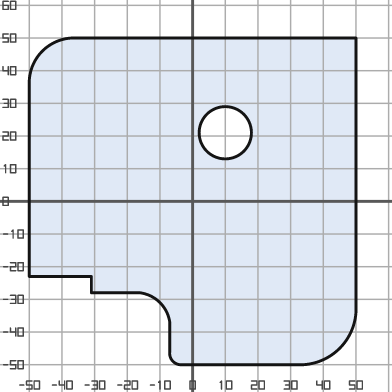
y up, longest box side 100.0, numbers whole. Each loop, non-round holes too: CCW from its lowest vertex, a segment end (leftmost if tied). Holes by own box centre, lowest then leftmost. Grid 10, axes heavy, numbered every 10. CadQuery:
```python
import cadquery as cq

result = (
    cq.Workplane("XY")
    .moveTo(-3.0, -50.0)
    .lineTo(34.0, -50.0)
    .threePointArc((45.0, -45.0), (50.0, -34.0))
    .lineTo(50.0, 50.0)
    .lineTo(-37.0, 50.0)
    .threePointArc((-46.0, 46.0), (-50.0, 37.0))
    .lineTo(-50.0, -23.0)
    .lineTo(-31.0, -23.0)
    .lineTo(-31.0, -28.0)
    .lineTo(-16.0, -28.0)
    .threePointArc((-10.0, -31.0), (-7.0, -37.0))
    .lineTo(-7.0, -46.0)
    .threePointArc((-6.0, -49.0), (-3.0, -50.0))
    .close()
    .moveTo(10.0, 21.0)
    .circle(8.0)
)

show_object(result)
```